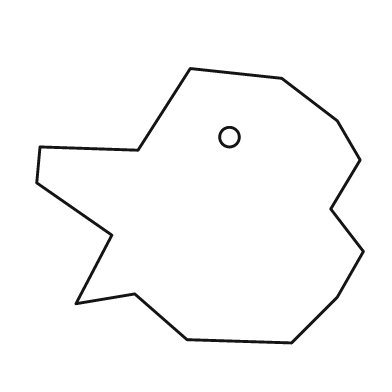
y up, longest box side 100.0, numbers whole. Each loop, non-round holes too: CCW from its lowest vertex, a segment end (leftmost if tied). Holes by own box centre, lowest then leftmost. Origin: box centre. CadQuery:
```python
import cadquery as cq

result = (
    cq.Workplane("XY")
    .moveTo(28.0, -42.0)
    .lineTo(42.0, -28.0)
    .lineTo(50.0, -14.0)
    .lineTo(40.0, -1.0)
    .lineTo(49.0, 14.0)
    .lineTo(42.0, 26.0)
    .lineTo(25.0, 39.0)
    .lineTo(-3.0, 42.0)
    .lineTo(-19.0, 17.0)
    .lineTo(-49.0, 18.0)
    .lineTo(-50.0, 7.0)
    .lineTo(-27.0, -9.0)
    .lineTo(-38.0, -30.0)
    .lineTo(-20.0, -27.0)
    .lineTo(-4.0, -41.0)
    .close()
    .moveTo(9.0, 21.0)
    .circle(3.0)
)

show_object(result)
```